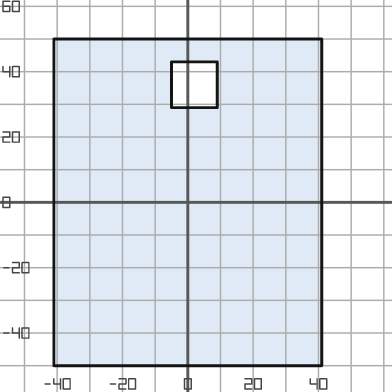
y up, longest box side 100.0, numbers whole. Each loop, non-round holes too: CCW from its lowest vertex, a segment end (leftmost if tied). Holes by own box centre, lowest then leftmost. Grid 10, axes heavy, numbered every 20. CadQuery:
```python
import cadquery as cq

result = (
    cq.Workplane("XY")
    .moveTo(-41.0, -50.0)
    .lineTo(41.0, -50.0)
    .lineTo(41.0, 50.0)
    .lineTo(-41.0, 50.0)
    .close()
    .moveTo(-5.0, 29.0)
    .lineTo(9.0, 29.0)
    .lineTo(9.0, 43.0)
    .lineTo(-5.0, 43.0)
    .close()
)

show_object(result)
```